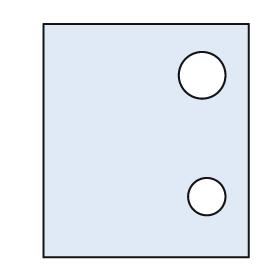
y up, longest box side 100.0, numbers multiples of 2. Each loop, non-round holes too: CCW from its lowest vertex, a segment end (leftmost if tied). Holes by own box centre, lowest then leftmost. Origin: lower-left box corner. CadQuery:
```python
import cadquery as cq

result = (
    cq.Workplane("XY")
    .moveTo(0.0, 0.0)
    .lineTo(88.0, 0.0)
    .lineTo(88.0, 100.0)
    .lineTo(0.0, 100.0)
    .close()
    .moveTo(70.0, 26.0)
    .circle(8.0)
    .moveTo(68.0, 78.0)
    .circle(10.0)
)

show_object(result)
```